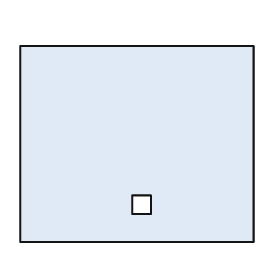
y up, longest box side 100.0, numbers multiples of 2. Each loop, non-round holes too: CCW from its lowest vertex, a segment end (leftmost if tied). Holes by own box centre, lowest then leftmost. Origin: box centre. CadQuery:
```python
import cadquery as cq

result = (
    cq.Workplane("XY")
    .moveTo(-50.0, -42.0)
    .lineTo(50.0, -42.0)
    .lineTo(50.0, 42.0)
    .lineTo(-50.0, 42.0)
    .close()
    .moveTo(-2.0, -30.0)
    .lineTo(6.0, -30.0)
    .lineTo(6.0, -22.0)
    .lineTo(-2.0, -22.0)
    .close()
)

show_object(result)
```